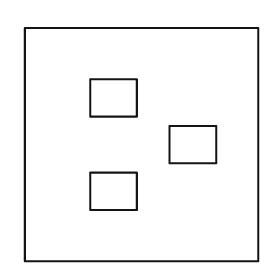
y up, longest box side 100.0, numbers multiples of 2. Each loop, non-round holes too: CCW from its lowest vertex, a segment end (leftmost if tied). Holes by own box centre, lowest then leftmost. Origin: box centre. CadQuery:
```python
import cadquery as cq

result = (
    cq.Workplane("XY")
    .moveTo(-50.0, -50.0)
    .lineTo(50.0, -50.0)
    .lineTo(50.0, 50.0)
    .lineTo(-50.0, 50.0)
    .close()
    .moveTo(-22.0, -28.0)
    .lineTo(-2.0, -28.0)
    .lineTo(-2.0, -12.0)
    .lineTo(-22.0, -12.0)
    .close()
    .moveTo(12.0, -8.0)
    .lineTo(32.0, -8.0)
    .lineTo(32.0, 8.0)
    .lineTo(12.0, 8.0)
    .close()
    .moveTo(-22.0, 12.0)
    .lineTo(-2.0, 12.0)
    .lineTo(-2.0, 28.0)
    .lineTo(-22.0, 28.0)
    .close()
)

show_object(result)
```